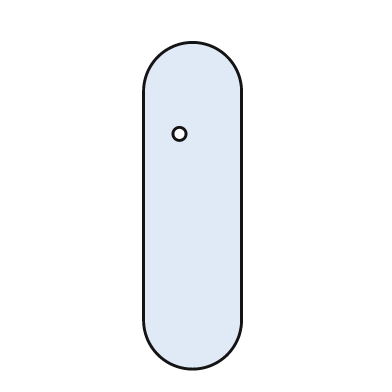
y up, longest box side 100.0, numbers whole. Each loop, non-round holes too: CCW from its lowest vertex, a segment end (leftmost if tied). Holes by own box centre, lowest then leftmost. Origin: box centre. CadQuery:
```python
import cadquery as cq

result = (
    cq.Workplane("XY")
    .moveTo(-15.0, -35.0)
    .threePointArc((0.0, -50.0), (15.0, -35.0))
    .lineTo(15.0, 35.0)
    .threePointArc((0.0, 50.0), (-15.0, 35.0))
    .close()
    .moveTo(-4.0, 22.0)
    .circle(2.0)
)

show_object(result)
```